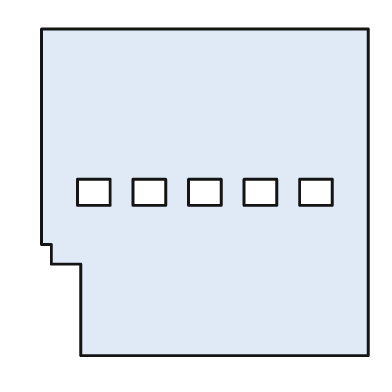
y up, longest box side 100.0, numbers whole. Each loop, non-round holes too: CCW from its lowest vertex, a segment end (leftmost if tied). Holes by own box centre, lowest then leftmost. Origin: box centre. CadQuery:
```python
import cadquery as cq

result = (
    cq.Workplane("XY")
    .moveTo(-38.0, -50.0)
    .lineTo(50.0, -50.0)
    .lineTo(50.0, 50.0)
    .lineTo(-50.0, 50.0)
    .lineTo(-50.0, -16.0)
    .lineTo(-47.0, -16.0)
    .lineTo(-47.0, -22.0)
    .lineTo(-38.0, -22.0)
    .close()
    .moveTo(-39.0, -4.0)
    .lineTo(-29.0, -4.0)
    .lineTo(-29.0, 4.0)
    .lineTo(-39.0, 4.0)
    .close()
    .moveTo(-22.0, -4.0)
    .lineTo(-12.0, -4.0)
    .lineTo(-12.0, 4.0)
    .lineTo(-22.0, 4.0)
    .close()
    .moveTo(-5.0, -4.0)
    .lineTo(5.0, -4.0)
    .lineTo(5.0, 4.0)
    .lineTo(-5.0, 4.0)
    .close()
    .moveTo(12.0, -4.0)
    .lineTo(22.0, -4.0)
    .lineTo(22.0, 4.0)
    .lineTo(12.0, 4.0)
    .close()
    .moveTo(29.0, -4.0)
    .lineTo(39.0, -4.0)
    .lineTo(39.0, 4.0)
    .lineTo(29.0, 4.0)
    .close()
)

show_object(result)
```